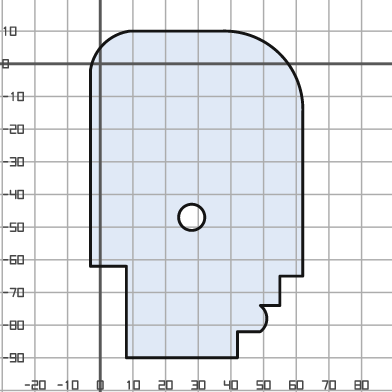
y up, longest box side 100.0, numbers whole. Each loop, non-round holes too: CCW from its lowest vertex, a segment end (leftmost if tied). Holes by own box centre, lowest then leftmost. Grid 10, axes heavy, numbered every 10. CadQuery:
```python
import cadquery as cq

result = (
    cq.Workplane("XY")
    .moveTo(8.0, -90.0)
    .lineTo(42.0, -90.0)
    .lineTo(42.0, -82.0)
    .lineTo(49.0, -82.0)
    .threePointArc((51.0, -78.0), (49.0, -74.0))
    .lineTo(55.0, -74.0)
    .lineTo(55.0, -65.0)
    .lineTo(62.0, -65.0)
    .lineTo(62.0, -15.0)
    .threePointArc((55.0, 3.0), (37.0, 10.0))
    .lineTo(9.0, 10.0)
    .threePointArc((1.0, 6.0), (-3.0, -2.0))
    .lineTo(-3.0, -62.0)
    .lineTo(8.0, -62.0)
    .close()
    .moveTo(28.0, -47.0)
    .circle(4.0)
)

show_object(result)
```